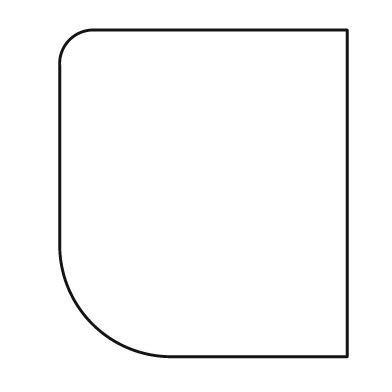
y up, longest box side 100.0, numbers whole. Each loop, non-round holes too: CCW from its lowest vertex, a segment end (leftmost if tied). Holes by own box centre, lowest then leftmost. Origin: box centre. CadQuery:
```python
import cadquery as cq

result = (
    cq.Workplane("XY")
    .moveTo(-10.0, -50.0)
    .lineTo(44.0, -50.0)
    .lineTo(44.0, 50.0)
    .lineTo(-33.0, 50.0)
    .threePointArc((-41.0, 47.0), (-44.0, 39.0))
    .lineTo(-44.0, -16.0)
    .threePointArc((-34.0, -40.0), (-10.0, -50.0))
    .close()
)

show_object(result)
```